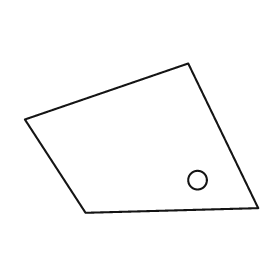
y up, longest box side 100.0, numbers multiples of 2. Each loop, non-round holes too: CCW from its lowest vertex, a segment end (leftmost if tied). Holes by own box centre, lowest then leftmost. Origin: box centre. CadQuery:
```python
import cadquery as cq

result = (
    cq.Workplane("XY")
    .moveTo(-24.0, -32.0)
    .lineTo(50.0, -30.0)
    .lineTo(20.0, 32.0)
    .lineTo(-50.0, 8.0)
    .close()
    .moveTo(24.0, -18.0)
    .circle(4.0)
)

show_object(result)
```